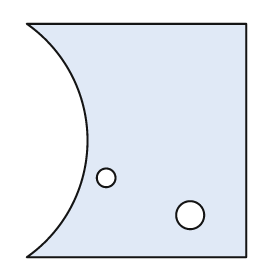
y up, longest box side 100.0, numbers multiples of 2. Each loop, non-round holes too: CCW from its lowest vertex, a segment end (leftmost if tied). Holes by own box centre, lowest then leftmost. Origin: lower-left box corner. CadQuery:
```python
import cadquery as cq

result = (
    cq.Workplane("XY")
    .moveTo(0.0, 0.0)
    .lineTo(94.0, 0.0)
    .lineTo(94.0, 100.0)
    .lineTo(0.0, 100.0)
    .threePointArc((26.0, 50.0), (0.0, 0.0))
    .close()
    .moveTo(70.0, 18.0)
    .circle(6.0)
    .moveTo(34.0, 34.0)
    .circle(4.0)
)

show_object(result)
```